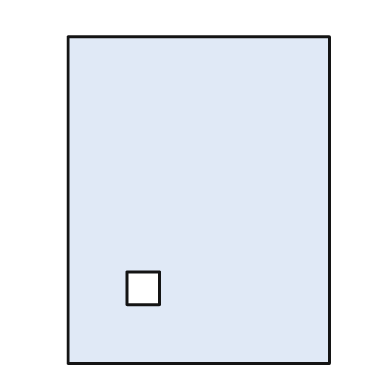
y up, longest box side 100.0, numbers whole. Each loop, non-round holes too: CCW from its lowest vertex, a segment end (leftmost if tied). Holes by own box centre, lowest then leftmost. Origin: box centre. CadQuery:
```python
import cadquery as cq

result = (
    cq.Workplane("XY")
    .moveTo(-40.0, -50.0)
    .lineTo(40.0, -50.0)
    .lineTo(40.0, 50.0)
    .lineTo(-40.0, 50.0)
    .close()
    .moveTo(-22.0, -32.0)
    .lineTo(-12.0, -32.0)
    .lineTo(-12.0, -22.0)
    .lineTo(-22.0, -22.0)
    .close()
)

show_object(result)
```